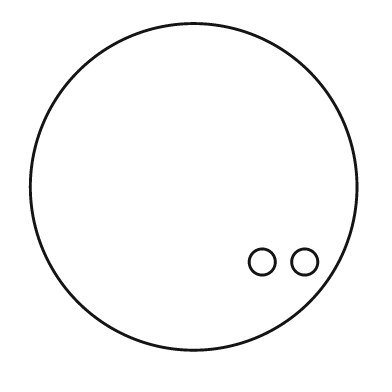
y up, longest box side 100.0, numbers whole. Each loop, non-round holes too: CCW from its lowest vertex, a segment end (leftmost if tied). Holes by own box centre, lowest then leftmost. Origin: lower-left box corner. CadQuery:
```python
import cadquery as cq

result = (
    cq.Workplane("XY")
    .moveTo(50.0, 50.0)
    .circle(50.0)
    .moveTo(71.0, 27.0)
    .circle(4.0)
    .moveTo(84.0, 27.0)
    .circle(4.0)
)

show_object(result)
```